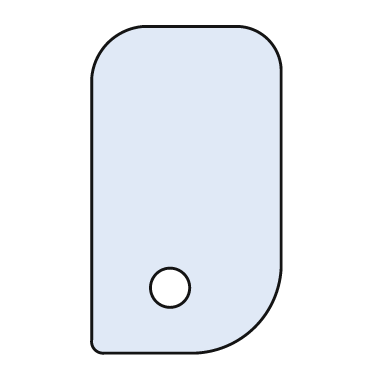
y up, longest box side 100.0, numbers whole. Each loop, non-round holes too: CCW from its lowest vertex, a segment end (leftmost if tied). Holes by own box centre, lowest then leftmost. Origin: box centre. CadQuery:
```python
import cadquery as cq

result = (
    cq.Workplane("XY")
    .moveTo(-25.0, -50.0)
    .lineTo(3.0, -50.0)
    .threePointArc((21.0, -42.0), (29.0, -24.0))
    .lineTo(29.0, 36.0)
    .threePointArc((25.0, 46.0), (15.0, 50.0))
    .lineTo(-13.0, 50.0)
    .threePointArc((-24.0, 45.0), (-29.0, 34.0))
    .lineTo(-29.0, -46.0)
    .threePointArc((-28.0, -49.0), (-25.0, -50.0))
    .close()
    .moveTo(-5.0, -30.0)
    .circle(6.0)
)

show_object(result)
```